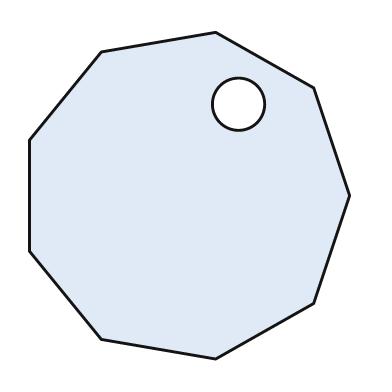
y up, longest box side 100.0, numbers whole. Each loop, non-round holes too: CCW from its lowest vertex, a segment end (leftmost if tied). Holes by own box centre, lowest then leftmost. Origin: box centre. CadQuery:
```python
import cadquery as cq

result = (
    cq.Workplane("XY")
    .moveTo(8.0, -50.0)
    .lineTo(38.0, -33.0)
    .lineTo(49.0, 0.0)
    .lineTo(38.0, 33.0)
    .lineTo(8.0, 50.0)
    .lineTo(-27.0, 44.0)
    .lineTo(-49.0, 17.0)
    .lineTo(-49.0, -17.0)
    .lineTo(-27.0, -44.0)
    .close()
    .moveTo(15.0, 28.0)
    .circle(8.0)
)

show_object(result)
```